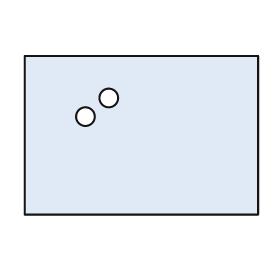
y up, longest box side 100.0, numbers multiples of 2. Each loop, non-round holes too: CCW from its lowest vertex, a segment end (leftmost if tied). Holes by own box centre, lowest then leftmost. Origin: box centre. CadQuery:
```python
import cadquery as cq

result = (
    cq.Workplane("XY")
    .moveTo(-50.0, -34.0)
    .lineTo(50.0, -34.0)
    .lineTo(50.0, 34.0)
    .lineTo(-50.0, 34.0)
    .close()
    .moveTo(-24.0, 8.0)
    .circle(4.0)
    .moveTo(-14.0, 16.0)
    .circle(4.0)
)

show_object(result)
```